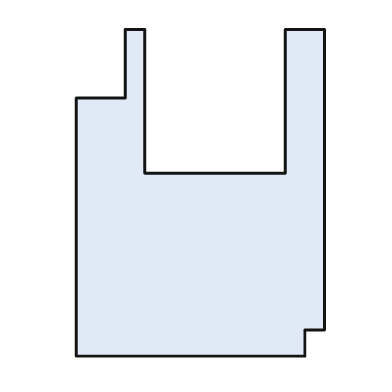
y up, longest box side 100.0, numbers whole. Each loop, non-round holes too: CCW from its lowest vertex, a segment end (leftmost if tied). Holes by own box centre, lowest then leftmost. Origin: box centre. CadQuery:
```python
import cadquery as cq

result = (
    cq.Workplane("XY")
    .moveTo(-38.0, -50.0)
    .lineTo(32.0, -50.0)
    .lineTo(32.0, -42.0)
    .lineTo(38.0, -42.0)
    .lineTo(38.0, 50.0)
    .lineTo(26.0, 50.0)
    .lineTo(26.0, 6.0)
    .lineTo(-17.0, 6.0)
    .lineTo(-17.0, 50.0)
    .lineTo(-23.0, 50.0)
    .lineTo(-23.0, 29.0)
    .lineTo(-38.0, 29.0)
    .close()
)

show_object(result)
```